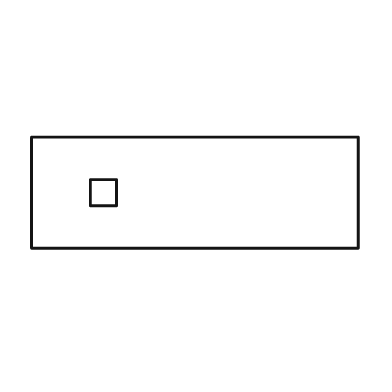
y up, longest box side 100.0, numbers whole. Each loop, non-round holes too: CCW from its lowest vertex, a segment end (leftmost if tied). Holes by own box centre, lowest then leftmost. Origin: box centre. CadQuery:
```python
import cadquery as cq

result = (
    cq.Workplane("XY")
    .moveTo(-50.0, -17.0)
    .lineTo(50.0, -17.0)
    .lineTo(50.0, 17.0)
    .lineTo(-50.0, 17.0)
    .close()
    .moveTo(-32.0, -4.0)
    .lineTo(-24.0, -4.0)
    .lineTo(-24.0, 4.0)
    .lineTo(-32.0, 4.0)
    .close()
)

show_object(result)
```